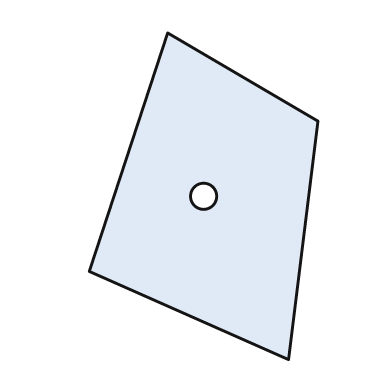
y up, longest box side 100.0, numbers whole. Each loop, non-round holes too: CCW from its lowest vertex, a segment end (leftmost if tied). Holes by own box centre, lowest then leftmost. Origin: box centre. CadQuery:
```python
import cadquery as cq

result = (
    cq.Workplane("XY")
    .moveTo(26.0, -50.0)
    .lineTo(35.0, 23.0)
    .lineTo(-11.0, 50.0)
    .lineTo(-35.0, -23.0)
    .close()
    .moveTo(0.0, 0.0)
    .circle(4.0)
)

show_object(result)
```